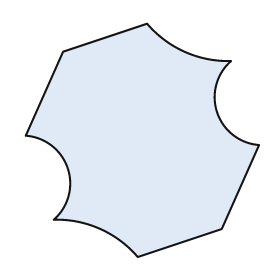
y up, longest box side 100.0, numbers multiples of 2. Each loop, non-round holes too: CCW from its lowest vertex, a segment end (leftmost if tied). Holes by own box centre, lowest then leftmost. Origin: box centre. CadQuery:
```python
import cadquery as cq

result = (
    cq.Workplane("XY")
    .moveTo(-2.0, -50.0)
    .lineTo(34.0, -38.0)
    .lineTo(50.0, -2.0)
    .threePointArc((32.0, 12.0), (38.0, 34.0))
    .threePointArc((18.0, 38.0), (2.0, 50.0))
    .lineTo(-34.0, 38.0)
    .lineTo(-50.0, 2.0)
    .threePointArc((-32.0, -12.0), (-38.0, -34.0))
    .threePointArc((-18.0, -38.0), (-2.0, -50.0))
    .close()
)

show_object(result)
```